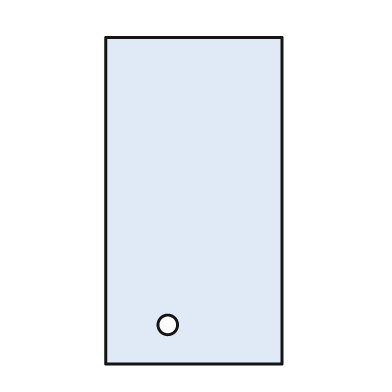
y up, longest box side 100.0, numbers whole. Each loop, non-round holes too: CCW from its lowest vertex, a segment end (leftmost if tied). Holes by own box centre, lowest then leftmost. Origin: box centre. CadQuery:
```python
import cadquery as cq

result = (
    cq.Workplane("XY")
    .moveTo(-27.0, -50.0)
    .lineTo(27.0, -50.0)
    .lineTo(27.0, 50.0)
    .lineTo(-27.0, 50.0)
    .close()
    .moveTo(-8.0, -38.0)
    .circle(3.0)
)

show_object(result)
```